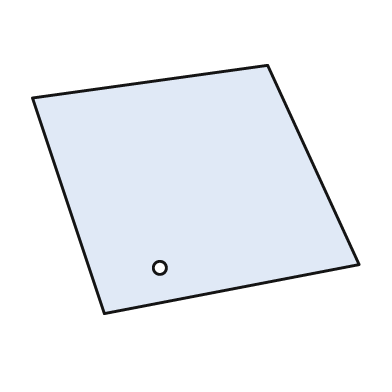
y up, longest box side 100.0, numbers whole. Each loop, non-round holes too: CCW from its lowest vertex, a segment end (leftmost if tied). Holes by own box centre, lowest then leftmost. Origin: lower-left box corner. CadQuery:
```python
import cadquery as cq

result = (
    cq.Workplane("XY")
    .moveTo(22.0, 0.0)
    .lineTo(100.0, 15.0)
    .lineTo(72.0, 76.0)
    .lineTo(0.0, 66.0)
    .close()
    .moveTo(39.0, 14.0)
    .circle(2.0)
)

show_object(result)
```